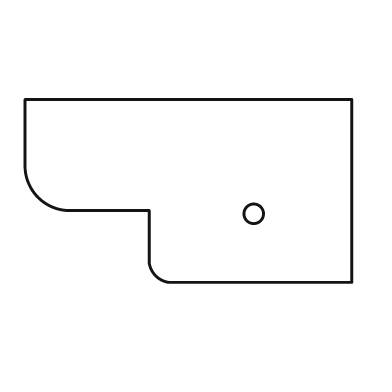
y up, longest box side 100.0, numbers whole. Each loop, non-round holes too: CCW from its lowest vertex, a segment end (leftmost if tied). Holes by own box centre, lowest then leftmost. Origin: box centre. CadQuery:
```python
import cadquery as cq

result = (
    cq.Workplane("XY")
    .moveTo(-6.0, -28.0)
    .lineTo(50.0, -28.0)
    .lineTo(50.0, 28.0)
    .lineTo(-50.0, 28.0)
    .lineTo(-50.0, 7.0)
    .threePointArc((-46.0, -2.0), (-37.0, -6.0))
    .lineTo(-12.0, -6.0)
    .lineTo(-12.0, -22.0)
    .threePointArc((-10.0, -26.0), (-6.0, -28.0))
    .close()
    .moveTo(20.0, -7.0)
    .circle(3.0)
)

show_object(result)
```